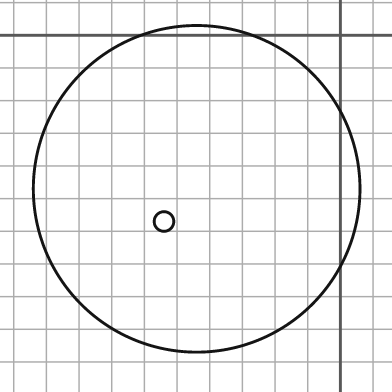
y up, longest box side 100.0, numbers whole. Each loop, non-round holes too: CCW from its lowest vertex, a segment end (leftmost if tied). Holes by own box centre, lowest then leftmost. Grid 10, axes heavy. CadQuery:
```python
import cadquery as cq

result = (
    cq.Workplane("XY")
    .moveTo(-44.0, -47.0)
    .circle(50.0)
    .moveTo(-54.0, -57.0)
    .circle(3.0)
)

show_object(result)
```